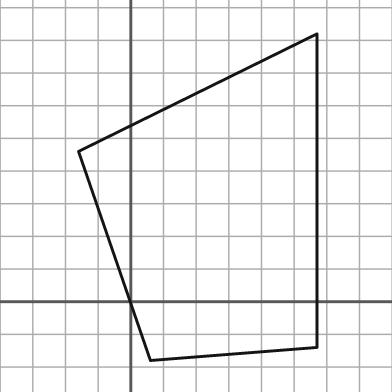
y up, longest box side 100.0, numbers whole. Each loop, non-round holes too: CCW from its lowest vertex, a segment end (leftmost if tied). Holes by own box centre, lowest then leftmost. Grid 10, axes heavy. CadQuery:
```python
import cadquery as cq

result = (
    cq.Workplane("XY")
    .moveTo(6.0, -18.0)
    .lineTo(57.0, -14.0)
    .lineTo(57.0, 82.0)
    .lineTo(-16.0, 46.0)
    .close()
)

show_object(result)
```